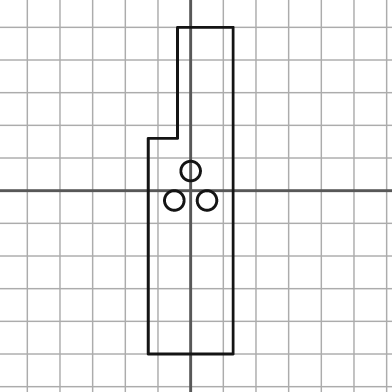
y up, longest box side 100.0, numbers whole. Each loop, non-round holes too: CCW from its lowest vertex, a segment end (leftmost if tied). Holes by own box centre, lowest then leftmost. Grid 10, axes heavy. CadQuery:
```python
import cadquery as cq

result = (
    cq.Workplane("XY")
    .moveTo(-13.0, -50.0)
    .lineTo(13.0, -50.0)
    .lineTo(13.0, 50.0)
    .lineTo(-4.0, 50.0)
    .lineTo(-4.0, 16.0)
    .lineTo(-13.0, 16.0)
    .close()
    .moveTo(-5.0, -3.0)
    .circle(3.0)
    .moveTo(5.0, -3.0)
    .circle(3.0)
    .moveTo(0.0, 6.0)
    .circle(3.0)
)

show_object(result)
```